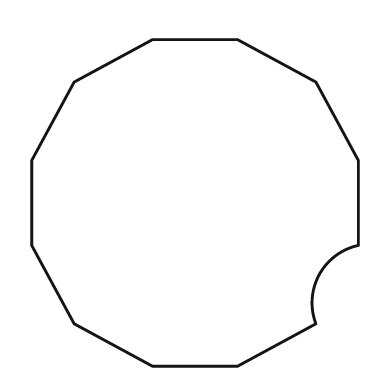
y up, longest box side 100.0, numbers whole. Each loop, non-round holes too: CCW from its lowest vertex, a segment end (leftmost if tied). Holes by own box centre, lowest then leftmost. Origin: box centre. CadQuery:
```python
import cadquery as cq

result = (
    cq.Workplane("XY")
    .moveTo(-13.0, -50.0)
    .lineTo(13.0, -50.0)
    .lineTo(37.0, -37.0)
    .threePointArc((38.0, -22.0), (50.0, -13.0))
    .lineTo(50.0, 13.0)
    .lineTo(37.0, 37.0)
    .lineTo(13.0, 50.0)
    .lineTo(-13.0, 50.0)
    .lineTo(-37.0, 37.0)
    .lineTo(-50.0, 13.0)
    .lineTo(-50.0, -13.0)
    .lineTo(-37.0, -37.0)
    .close()
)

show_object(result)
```